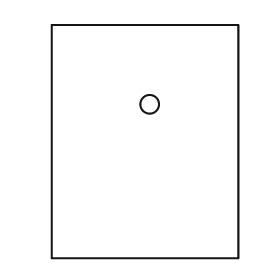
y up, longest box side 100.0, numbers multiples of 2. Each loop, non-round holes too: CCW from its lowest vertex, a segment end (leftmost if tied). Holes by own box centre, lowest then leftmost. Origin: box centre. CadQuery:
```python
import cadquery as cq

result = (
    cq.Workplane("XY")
    .moveTo(-40.0, -50.0)
    .lineTo(40.0, -50.0)
    .lineTo(40.0, 50.0)
    .lineTo(-40.0, 50.0)
    .close()
    .moveTo(2.0, 16.0)
    .circle(4.0)
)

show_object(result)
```